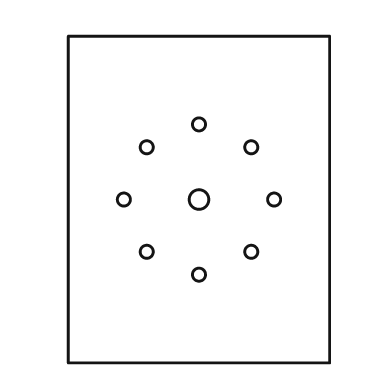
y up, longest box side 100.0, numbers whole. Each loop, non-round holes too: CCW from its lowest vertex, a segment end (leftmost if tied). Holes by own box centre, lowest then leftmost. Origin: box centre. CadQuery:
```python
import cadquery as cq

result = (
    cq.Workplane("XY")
    .moveTo(-40.0, -50.0)
    .lineTo(40.0, -50.0)
    .lineTo(40.0, 50.0)
    .lineTo(-40.0, 50.0)
    .close()
    .moveTo(0.0, -23.0)
    .circle(2.0)
    .moveTo(-16.0, -16.0)
    .circle(2.0)
    .moveTo(16.0, -16.0)
    .circle(2.0)
    .moveTo(-23.0, 0.0)
    .circle(2.0)
    .moveTo(0.0, 0.0)
    .circle(3.0)
    .moveTo(23.0, 0.0)
    .circle(2.0)
    .moveTo(-16.0, 16.0)
    .circle(2.0)
    .moveTo(16.0, 16.0)
    .circle(2.0)
    .moveTo(0.0, 23.0)
    .circle(2.0)
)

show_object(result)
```